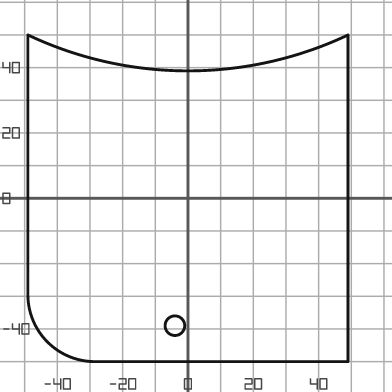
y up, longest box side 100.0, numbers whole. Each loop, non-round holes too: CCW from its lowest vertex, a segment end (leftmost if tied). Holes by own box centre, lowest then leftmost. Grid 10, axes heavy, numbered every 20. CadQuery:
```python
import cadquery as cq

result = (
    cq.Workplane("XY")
    .moveTo(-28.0, -50.0)
    .lineTo(49.0, -50.0)
    .lineTo(49.0, 50.0)
    .threePointArc((0.0, 39.0), (-49.0, 50.0))
    .lineTo(-49.0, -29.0)
    .threePointArc((-43.0, -44.0), (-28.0, -50.0))
    .close()
    .moveTo(-4.0, -39.0)
    .circle(3.0)
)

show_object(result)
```